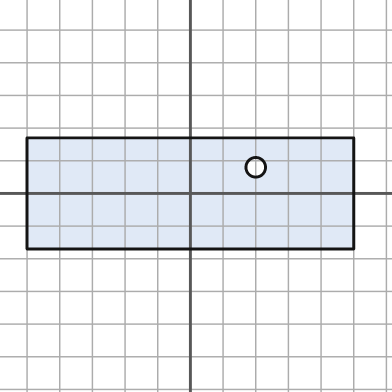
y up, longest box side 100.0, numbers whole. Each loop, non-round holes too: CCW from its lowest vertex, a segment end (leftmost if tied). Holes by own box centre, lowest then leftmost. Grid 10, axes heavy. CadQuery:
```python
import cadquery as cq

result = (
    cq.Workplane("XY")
    .moveTo(-50.0, -17.0)
    .lineTo(50.0, -17.0)
    .lineTo(50.0, 17.0)
    .lineTo(-50.0, 17.0)
    .close()
    .moveTo(20.0, 8.0)
    .circle(3.0)
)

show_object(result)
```